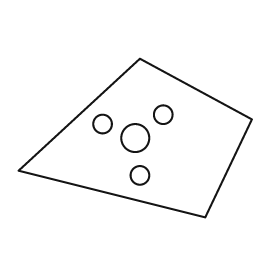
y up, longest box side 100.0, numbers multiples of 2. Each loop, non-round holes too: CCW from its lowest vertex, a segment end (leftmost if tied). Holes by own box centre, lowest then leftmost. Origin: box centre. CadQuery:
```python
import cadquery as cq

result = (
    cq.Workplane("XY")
    .moveTo(30.0, -34.0)
    .lineTo(50.0, 8.0)
    .lineTo(2.0, 34.0)
    .lineTo(-50.0, -14.0)
    .close()
    .moveTo(2.0, -16.0)
    .circle(4.0)
    .moveTo(0.0, 0.0)
    .circle(6.0)
    .moveTo(-14.0, 6.0)
    .circle(4.0)
    .moveTo(12.0, 10.0)
    .circle(4.0)
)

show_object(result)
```